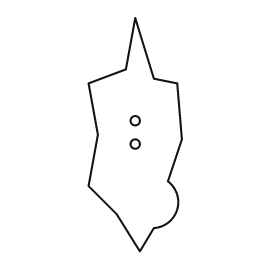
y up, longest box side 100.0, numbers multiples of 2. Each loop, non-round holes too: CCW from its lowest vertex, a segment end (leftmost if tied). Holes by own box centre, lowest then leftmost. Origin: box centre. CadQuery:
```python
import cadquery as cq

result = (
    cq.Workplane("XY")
    .moveTo(2.0, -50.0)
    .lineTo(8.0, -40.0)
    .threePointArc((18.0, -32.0), (14.0, -20.0))
    .lineTo(20.0, -2.0)
    .lineTo(18.0, 22.0)
    .lineTo(8.0, 24.0)
    .lineTo(0.0, 50.0)
    .lineTo(-4.0, 28.0)
    .lineTo(-20.0, 22.0)
    .lineTo(-16.0, 0.0)
    .lineTo(-20.0, -22.0)
    .lineTo(-8.0, -34.0)
    .close()
    .moveTo(0.0, -4.0)
    .circle(2.0)
    .moveTo(0.0, 6.0)
    .circle(2.0)
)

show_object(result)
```